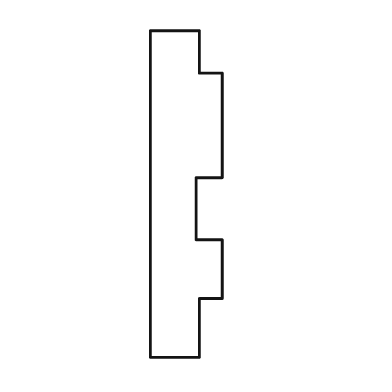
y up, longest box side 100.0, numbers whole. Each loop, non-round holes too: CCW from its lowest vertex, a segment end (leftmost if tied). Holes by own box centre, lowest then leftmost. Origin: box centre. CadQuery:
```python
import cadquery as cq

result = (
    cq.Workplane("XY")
    .moveTo(-11.0, -50.0)
    .lineTo(4.0, -50.0)
    .lineTo(4.0, -32.0)
    .lineTo(11.0, -32.0)
    .lineTo(11.0, -14.0)
    .lineTo(3.0, -14.0)
    .lineTo(3.0, 5.0)
    .lineTo(11.0, 5.0)
    .lineTo(11.0, 37.0)
    .lineTo(4.0, 37.0)
    .lineTo(4.0, 50.0)
    .lineTo(-11.0, 50.0)
    .close()
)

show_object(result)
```